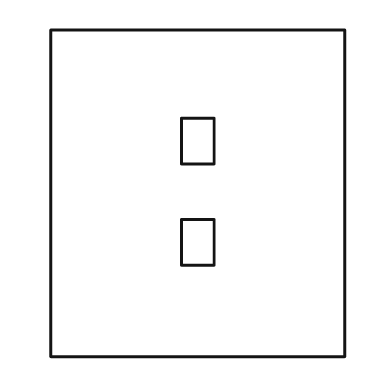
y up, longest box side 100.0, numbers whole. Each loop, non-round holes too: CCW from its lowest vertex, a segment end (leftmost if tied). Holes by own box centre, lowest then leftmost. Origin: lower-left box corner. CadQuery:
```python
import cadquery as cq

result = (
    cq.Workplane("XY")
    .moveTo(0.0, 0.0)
    .lineTo(90.0, 0.0)
    .lineTo(90.0, 100.0)
    .lineTo(0.0, 100.0)
    .close()
    .moveTo(40.0, 28.0)
    .lineTo(50.0, 28.0)
    .lineTo(50.0, 42.0)
    .lineTo(40.0, 42.0)
    .close()
    .moveTo(40.0, 59.0)
    .lineTo(50.0, 59.0)
    .lineTo(50.0, 73.0)
    .lineTo(40.0, 73.0)
    .close()
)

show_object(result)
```